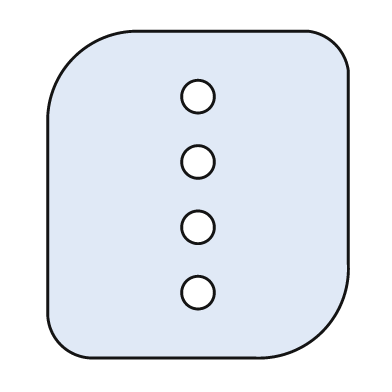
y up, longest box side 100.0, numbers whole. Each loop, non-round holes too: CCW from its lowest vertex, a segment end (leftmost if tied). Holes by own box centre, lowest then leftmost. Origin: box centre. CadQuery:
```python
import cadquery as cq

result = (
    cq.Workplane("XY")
    .moveTo(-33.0, -50.0)
    .lineTo(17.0, -50.0)
    .threePointArc((38.0, -42.0), (46.0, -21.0))
    .lineTo(46.0, 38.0)
    .threePointArc((42.0, 46.0), (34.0, 50.0))
    .lineTo(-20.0, 50.0)
    .threePointArc((-38.0, 42.0), (-46.0, 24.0))
    .lineTo(-46.0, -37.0)
    .threePointArc((-42.0, -46.0), (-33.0, -50.0))
    .close()
    .moveTo(0.0, -30.0)
    .circle(5.0)
    .moveTo(0.0, -10.0)
    .circle(5.0)
    .moveTo(0.0, 10.0)
    .circle(5.0)
    .moveTo(0.0, 30.0)
    .circle(5.0)
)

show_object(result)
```